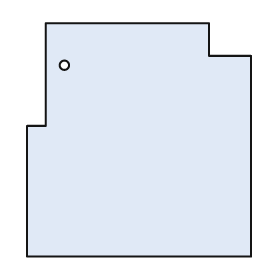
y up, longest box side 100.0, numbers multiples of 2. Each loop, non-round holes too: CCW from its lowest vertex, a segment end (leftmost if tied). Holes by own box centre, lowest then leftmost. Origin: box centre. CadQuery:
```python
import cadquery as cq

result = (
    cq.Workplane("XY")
    .moveTo(-48.0, -50.0)
    .lineTo(48.0, -50.0)
    .lineTo(48.0, 36.0)
    .lineTo(30.0, 36.0)
    .lineTo(30.0, 50.0)
    .lineTo(-40.0, 50.0)
    .lineTo(-40.0, 6.0)
    .lineTo(-48.0, 6.0)
    .close()
    .moveTo(-32.0, 32.0)
    .circle(2.0)
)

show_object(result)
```